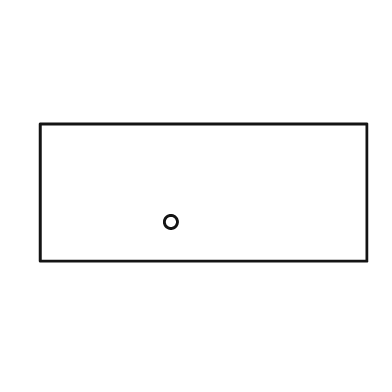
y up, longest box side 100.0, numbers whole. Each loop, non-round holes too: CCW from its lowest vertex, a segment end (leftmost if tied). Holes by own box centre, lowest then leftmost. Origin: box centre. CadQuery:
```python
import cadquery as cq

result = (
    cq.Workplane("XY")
    .moveTo(-50.0, -21.0)
    .lineTo(50.0, -21.0)
    .lineTo(50.0, 21.0)
    .lineTo(-50.0, 21.0)
    .close()
    .moveTo(-10.0, -9.0)
    .circle(2.0)
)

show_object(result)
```